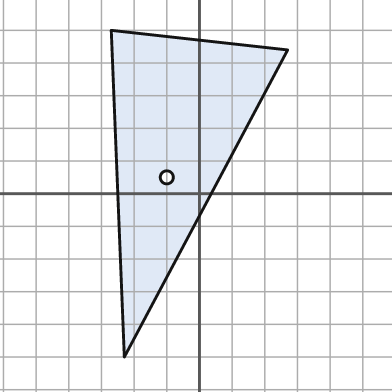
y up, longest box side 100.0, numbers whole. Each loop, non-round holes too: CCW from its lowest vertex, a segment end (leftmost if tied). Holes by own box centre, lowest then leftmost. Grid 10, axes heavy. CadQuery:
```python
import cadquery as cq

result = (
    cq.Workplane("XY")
    .moveTo(-23.0, -50.0)
    .lineTo(27.0, 44.0)
    .lineTo(-27.0, 50.0)
    .close()
    .moveTo(-10.0, 5.0)
    .circle(2.0)
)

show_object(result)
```